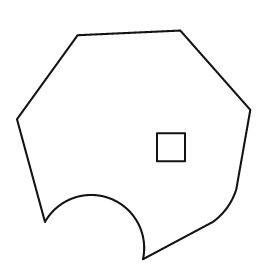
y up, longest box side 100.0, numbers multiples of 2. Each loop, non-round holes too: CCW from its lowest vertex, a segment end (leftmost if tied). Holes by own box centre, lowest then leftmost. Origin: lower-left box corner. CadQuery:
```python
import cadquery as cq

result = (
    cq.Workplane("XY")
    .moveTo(54.0, 0.0)
    .lineTo(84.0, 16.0)
    .threePointArc((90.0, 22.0), (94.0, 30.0))
    .lineTo(100.0, 64.0)
    .lineTo(70.0, 98.0)
    .lineTo(26.0, 96.0)
    .lineTo(0.0, 60.0)
    .lineTo(12.0, 16.0)
    .threePointArc((40.0, 26.0), (54.0, 0.0))
    .close()
    .moveTo(60.0, 42.0)
    .lineTo(72.0, 42.0)
    .lineTo(72.0, 54.0)
    .lineTo(60.0, 54.0)
    .close()
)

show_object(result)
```